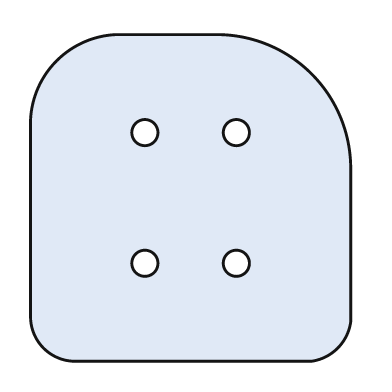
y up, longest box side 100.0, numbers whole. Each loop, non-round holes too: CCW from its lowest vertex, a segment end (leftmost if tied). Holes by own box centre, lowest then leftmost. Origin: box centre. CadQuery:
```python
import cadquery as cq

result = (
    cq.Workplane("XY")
    .moveTo(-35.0, -50.0)
    .lineTo(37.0, -50.0)
    .threePointArc((45.0, -46.0), (49.0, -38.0))
    .lineTo(49.0, 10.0)
    .threePointArc((37.0, 38.0), (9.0, 50.0))
    .lineTo(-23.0, 50.0)
    .threePointArc((-41.0, 42.0), (-49.0, 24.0))
    .lineTo(-49.0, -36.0)
    .threePointArc((-45.0, -46.0), (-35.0, -50.0))
    .close()
    .moveTo(-14.0, -20.0)
    .circle(4.0)
    .moveTo(14.0, -20.0)
    .circle(4.0)
    .moveTo(-14.0, 20.0)
    .circle(4.0)
    .moveTo(14.0, 20.0)
    .circle(4.0)
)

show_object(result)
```